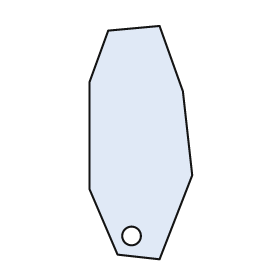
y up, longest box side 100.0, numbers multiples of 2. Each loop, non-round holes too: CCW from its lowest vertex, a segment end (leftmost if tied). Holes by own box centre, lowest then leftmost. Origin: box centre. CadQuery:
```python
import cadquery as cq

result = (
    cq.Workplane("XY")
    .moveTo(8.0, -50.0)
    .lineTo(22.0, -14.0)
    .lineTo(18.0, 22.0)
    .lineTo(8.0, 50.0)
    .lineTo(-14.0, 48.0)
    .lineTo(-22.0, 26.0)
    .lineTo(-22.0, -20.0)
    .lineTo(-10.0, -48.0)
    .close()
    .moveTo(-4.0, -40.0)
    .circle(4.0)
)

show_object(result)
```